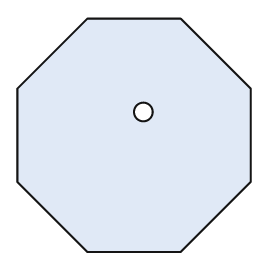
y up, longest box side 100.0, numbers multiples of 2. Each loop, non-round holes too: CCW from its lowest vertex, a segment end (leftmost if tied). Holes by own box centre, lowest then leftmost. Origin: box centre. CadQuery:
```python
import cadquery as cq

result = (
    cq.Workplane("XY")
    .moveTo(-20.0, -50.0)
    .lineTo(20.0, -50.0)
    .lineTo(50.0, -20.0)
    .lineTo(50.0, 20.0)
    .lineTo(20.0, 50.0)
    .lineTo(-20.0, 50.0)
    .lineTo(-50.0, 20.0)
    .lineTo(-50.0, -20.0)
    .close()
    .moveTo(4.0, 10.0)
    .circle(4.0)
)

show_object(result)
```